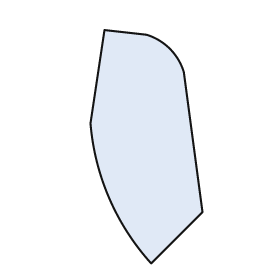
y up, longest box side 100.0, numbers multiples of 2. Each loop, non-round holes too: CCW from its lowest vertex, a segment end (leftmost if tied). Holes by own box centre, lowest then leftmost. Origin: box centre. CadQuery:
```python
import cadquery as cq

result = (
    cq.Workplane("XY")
    .moveTo(2.0, -50.0)
    .lineTo(24.0, -28.0)
    .lineTo(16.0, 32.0)
    .threePointArc((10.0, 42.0), (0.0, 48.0))
    .lineTo(-18.0, 50.0)
    .lineTo(-24.0, 10.0)
    .threePointArc((-16.0, -22.0), (2.0, -50.0))
    .close()
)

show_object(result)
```